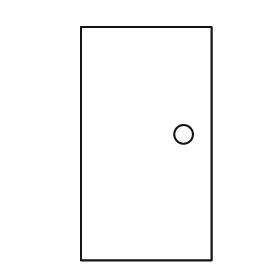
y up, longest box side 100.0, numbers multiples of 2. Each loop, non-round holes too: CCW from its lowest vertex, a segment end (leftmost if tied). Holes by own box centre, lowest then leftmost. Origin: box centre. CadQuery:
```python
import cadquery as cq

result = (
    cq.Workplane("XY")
    .moveTo(-28.0, -50.0)
    .lineTo(28.0, -50.0)
    .lineTo(28.0, 50.0)
    .lineTo(-28.0, 50.0)
    .close()
    .moveTo(16.0, 4.0)
    .circle(4.0)
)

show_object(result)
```